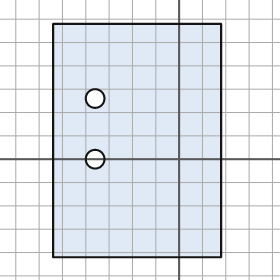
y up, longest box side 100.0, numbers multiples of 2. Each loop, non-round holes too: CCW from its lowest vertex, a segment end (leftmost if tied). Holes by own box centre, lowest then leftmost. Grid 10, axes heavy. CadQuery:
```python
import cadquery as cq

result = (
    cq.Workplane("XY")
    .moveTo(-54.0, -42.0)
    .lineTo(18.0, -42.0)
    .lineTo(18.0, 58.0)
    .lineTo(-54.0, 58.0)
    .close()
    .moveTo(-36.0, 0.0)
    .circle(4.0)
    .moveTo(-36.0, 26.0)
    .circle(4.0)
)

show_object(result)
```